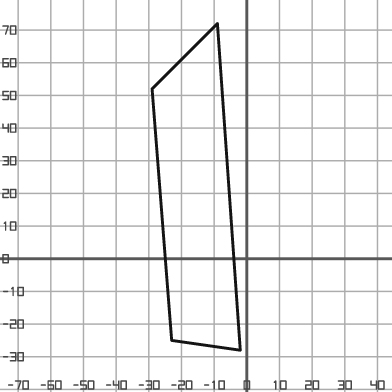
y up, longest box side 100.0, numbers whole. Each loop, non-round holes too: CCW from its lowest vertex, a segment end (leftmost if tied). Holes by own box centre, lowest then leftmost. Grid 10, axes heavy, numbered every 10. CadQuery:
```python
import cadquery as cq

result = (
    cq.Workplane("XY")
    .moveTo(-2.0, -28.0)
    .lineTo(-9.0, 72.0)
    .lineTo(-29.0, 52.0)
    .lineTo(-23.0, -25.0)
    .close()
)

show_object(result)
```